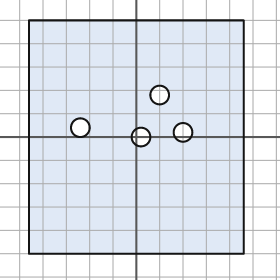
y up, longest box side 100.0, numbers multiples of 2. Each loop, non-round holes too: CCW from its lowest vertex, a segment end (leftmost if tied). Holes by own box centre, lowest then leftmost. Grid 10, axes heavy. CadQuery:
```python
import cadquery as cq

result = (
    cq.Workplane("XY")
    .moveTo(-46.0, -50.0)
    .lineTo(46.0, -50.0)
    .lineTo(46.0, 50.0)
    .lineTo(-46.0, 50.0)
    .close()
    .moveTo(2.0, 0.0)
    .circle(4.0)
    .moveTo(20.0, 2.0)
    .circle(4.0)
    .moveTo(-24.0, 4.0)
    .circle(4.0)
    .moveTo(10.0, 18.0)
    .circle(4.0)
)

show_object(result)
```